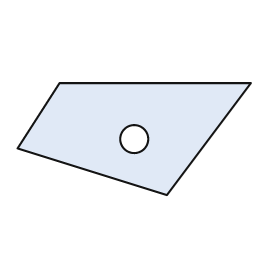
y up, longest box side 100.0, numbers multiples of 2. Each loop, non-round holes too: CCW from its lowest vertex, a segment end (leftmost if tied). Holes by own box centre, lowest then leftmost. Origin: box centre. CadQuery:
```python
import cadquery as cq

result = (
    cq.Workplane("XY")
    .moveTo(14.0, -24.0)
    .lineTo(50.0, 24.0)
    .lineTo(-32.0, 24.0)
    .lineTo(-50.0, -4.0)
    .close()
    .moveTo(0.0, 0.0)
    .circle(6.0)
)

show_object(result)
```